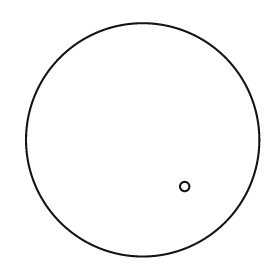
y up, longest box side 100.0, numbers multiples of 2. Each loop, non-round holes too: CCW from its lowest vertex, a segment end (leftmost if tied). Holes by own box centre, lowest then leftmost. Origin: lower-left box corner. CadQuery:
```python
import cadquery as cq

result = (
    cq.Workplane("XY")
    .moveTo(50.0, 50.0)
    .circle(50.0)
    .moveTo(68.0, 30.0)
    .circle(2.0)
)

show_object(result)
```